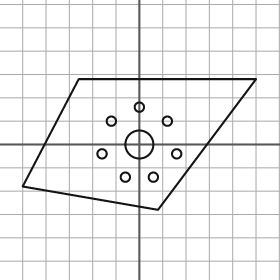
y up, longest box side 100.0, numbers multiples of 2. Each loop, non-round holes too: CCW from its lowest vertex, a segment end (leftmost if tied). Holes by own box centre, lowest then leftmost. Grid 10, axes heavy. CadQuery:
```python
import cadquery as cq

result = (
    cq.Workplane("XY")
    .moveTo(8.0, -28.0)
    .lineTo(50.0, 28.0)
    .lineTo(-26.0, 28.0)
    .lineTo(-50.0, -18.0)
    .close()
    .moveTo(-6.0, -14.0)
    .circle(2.0)
    .moveTo(6.0, -14.0)
    .circle(2.0)
    .moveTo(-16.0, -4.0)
    .circle(2.0)
    .moveTo(16.0, -4.0)
    .circle(2.0)
    .moveTo(0.0, 0.0)
    .circle(6.0)
    .moveTo(-12.0, 10.0)
    .circle(2.0)
    .moveTo(12.0, 10.0)
    .circle(2.0)
    .moveTo(0.0, 16.0)
    .circle(2.0)
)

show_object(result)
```